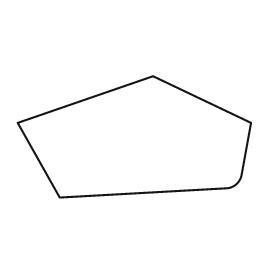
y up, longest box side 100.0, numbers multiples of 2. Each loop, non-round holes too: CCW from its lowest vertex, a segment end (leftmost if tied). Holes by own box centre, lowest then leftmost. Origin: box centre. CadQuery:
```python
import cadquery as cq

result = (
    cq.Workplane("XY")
    .moveTo(-32.0, -26.0)
    .lineTo(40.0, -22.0)
    .threePointArc((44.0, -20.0), (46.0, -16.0))
    .lineTo(50.0, 6.0)
    .lineTo(8.0, 26.0)
    .lineTo(-50.0, 6.0)
    .close()
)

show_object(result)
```